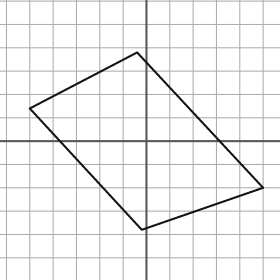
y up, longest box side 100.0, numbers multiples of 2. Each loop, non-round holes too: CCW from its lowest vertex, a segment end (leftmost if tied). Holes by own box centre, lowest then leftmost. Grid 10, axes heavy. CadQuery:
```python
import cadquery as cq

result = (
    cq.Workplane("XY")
    .moveTo(-2.0, -38.0)
    .lineTo(50.0, -20.0)
    .lineTo(-4.0, 38.0)
    .lineTo(-50.0, 14.0)
    .close()
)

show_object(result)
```